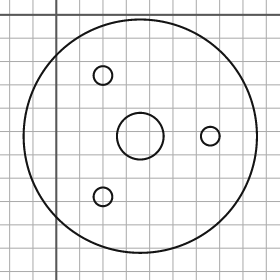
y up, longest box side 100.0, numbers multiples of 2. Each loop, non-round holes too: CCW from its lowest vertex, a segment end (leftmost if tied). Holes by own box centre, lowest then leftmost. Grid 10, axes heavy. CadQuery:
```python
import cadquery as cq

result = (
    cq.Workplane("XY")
    .moveTo(36.0, -52.0)
    .circle(50.0)
    .moveTo(20.0, -78.0)
    .circle(4.0)
    .moveTo(36.0, -52.0)
    .circle(10.0)
    .moveTo(66.0, -52.0)
    .circle(4.0)
    .moveTo(20.0, -26.0)
    .circle(4.0)
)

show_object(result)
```